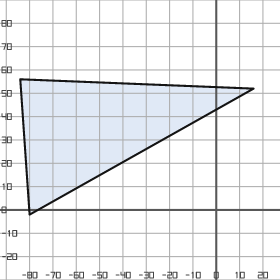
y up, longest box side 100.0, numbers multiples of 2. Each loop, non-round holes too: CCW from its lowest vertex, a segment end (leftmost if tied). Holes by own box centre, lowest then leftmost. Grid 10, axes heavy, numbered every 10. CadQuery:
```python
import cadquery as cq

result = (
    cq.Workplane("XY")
    .moveTo(-80.0, -2.0)
    .lineTo(16.0, 52.0)
    .lineTo(-84.0, 56.0)
    .close()
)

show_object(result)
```